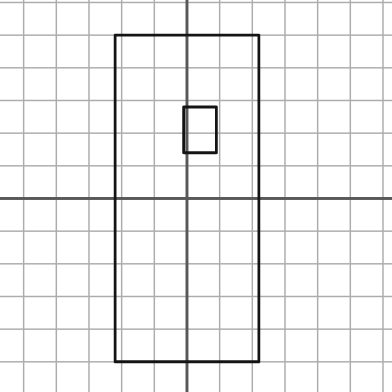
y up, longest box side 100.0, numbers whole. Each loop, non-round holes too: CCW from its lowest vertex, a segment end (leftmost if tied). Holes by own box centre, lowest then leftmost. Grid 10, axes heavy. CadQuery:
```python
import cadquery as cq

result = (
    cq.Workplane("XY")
    .moveTo(-22.0, -50.0)
    .lineTo(22.0, -50.0)
    .lineTo(22.0, 50.0)
    .lineTo(-22.0, 50.0)
    .close()
    .moveTo(-1.0, 14.0)
    .lineTo(9.0, 14.0)
    .lineTo(9.0, 28.0)
    .lineTo(-1.0, 28.0)
    .close()
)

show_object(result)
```